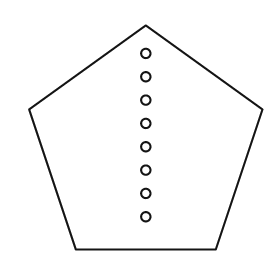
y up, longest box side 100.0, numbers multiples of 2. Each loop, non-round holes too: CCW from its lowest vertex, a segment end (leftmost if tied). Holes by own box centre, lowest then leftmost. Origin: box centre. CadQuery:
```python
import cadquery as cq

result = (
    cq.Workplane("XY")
    .moveTo(-30.0, -48.0)
    .lineTo(30.0, -48.0)
    .lineTo(50.0, 12.0)
    .lineTo(0.0, 48.0)
    .lineTo(-50.0, 12.0)
    .close()
    .moveTo(0.0, -34.0)
    .circle(2.0)
    .moveTo(0.0, -24.0)
    .circle(2.0)
    .moveTo(0.0, -14.0)
    .circle(2.0)
    .moveTo(0.0, -4.0)
    .circle(2.0)
    .moveTo(0.0, 6.0)
    .circle(2.0)
    .moveTo(0.0, 16.0)
    .circle(2.0)
    .moveTo(0.0, 26.0)
    .circle(2.0)
    .moveTo(0.0, 36.0)
    .circle(2.0)
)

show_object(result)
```